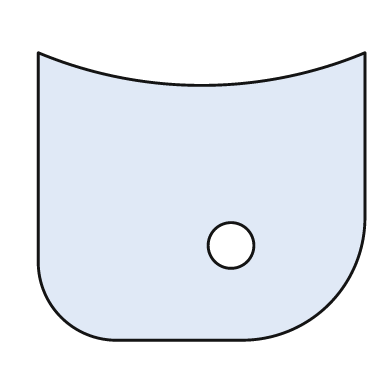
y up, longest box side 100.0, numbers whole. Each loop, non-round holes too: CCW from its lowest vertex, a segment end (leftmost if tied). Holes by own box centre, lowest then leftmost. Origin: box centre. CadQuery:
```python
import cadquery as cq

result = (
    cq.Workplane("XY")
    .moveTo(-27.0, -44.0)
    .lineTo(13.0, -44.0)
    .threePointArc((39.0, -33.0), (50.0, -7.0))
    .lineTo(50.0, 44.0)
    .threePointArc((0.0, 34.0), (-50.0, 44.0))
    .lineTo(-50.0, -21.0)
    .threePointArc((-43.0, -37.0), (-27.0, -44.0))
    .close()
    .moveTo(9.0, -15.0)
    .circle(7.0)
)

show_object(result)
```